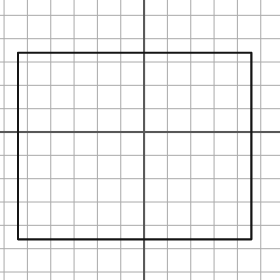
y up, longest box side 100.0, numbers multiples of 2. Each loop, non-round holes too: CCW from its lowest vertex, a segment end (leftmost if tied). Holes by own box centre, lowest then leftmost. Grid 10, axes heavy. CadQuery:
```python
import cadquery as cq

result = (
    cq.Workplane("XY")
    .moveTo(-54.0, -46.0)
    .lineTo(46.0, -46.0)
    .lineTo(46.0, 34.0)
    .lineTo(-54.0, 34.0)
    .close()
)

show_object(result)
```